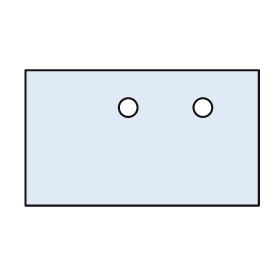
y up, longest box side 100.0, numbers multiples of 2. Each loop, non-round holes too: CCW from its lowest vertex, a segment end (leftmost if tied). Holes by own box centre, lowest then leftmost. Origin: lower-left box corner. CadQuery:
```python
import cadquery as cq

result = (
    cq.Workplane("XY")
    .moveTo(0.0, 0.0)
    .lineTo(100.0, 0.0)
    .lineTo(100.0, 58.0)
    .lineTo(0.0, 58.0)
    .close()
    .moveTo(44.0, 42.0)
    .circle(4.0)
    .moveTo(76.0, 42.0)
    .circle(4.0)
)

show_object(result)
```